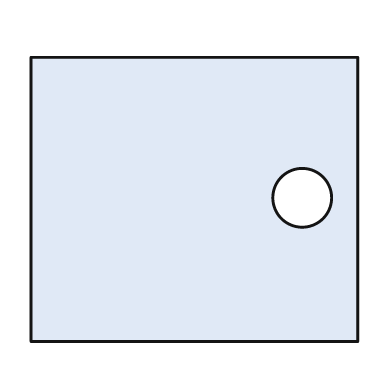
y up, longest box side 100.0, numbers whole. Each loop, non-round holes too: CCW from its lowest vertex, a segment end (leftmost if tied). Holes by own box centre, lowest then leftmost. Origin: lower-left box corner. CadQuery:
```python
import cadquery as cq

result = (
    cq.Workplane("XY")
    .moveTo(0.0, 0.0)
    .lineTo(100.0, 0.0)
    .lineTo(100.0, 87.0)
    .lineTo(0.0, 87.0)
    .close()
    .moveTo(83.0, 44.0)
    .circle(9.0)
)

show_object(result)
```